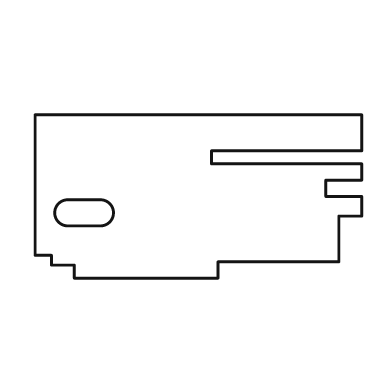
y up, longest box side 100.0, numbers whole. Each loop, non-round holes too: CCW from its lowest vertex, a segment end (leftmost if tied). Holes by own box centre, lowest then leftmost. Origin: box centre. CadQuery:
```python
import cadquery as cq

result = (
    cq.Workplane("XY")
    .moveTo(-38.0, -25.0)
    .lineTo(6.0, -25.0)
    .lineTo(6.0, -20.0)
    .lineTo(43.0, -20.0)
    .lineTo(43.0, -6.0)
    .lineTo(50.0, -6.0)
    .lineTo(50.0, 0.0)
    .lineTo(39.0, 0.0)
    .lineTo(39.0, 5.0)
    .lineTo(50.0, 5.0)
    .lineTo(50.0, 10.0)
    .lineTo(4.0, 10.0)
    .lineTo(4.0, 14.0)
    .lineTo(50.0, 14.0)
    .lineTo(50.0, 25.0)
    .lineTo(-50.0, 25.0)
    .lineTo(-50.0, -18.0)
    .lineTo(-45.0, -18.0)
    .lineTo(-45.0, -21.0)
    .lineTo(-38.0, -21.0)
    .close()
    .moveTo(-40.0, -9.0)
    .lineTo(-30.0, -9.0)
    .threePointArc((-26.0, -5.0), (-30.0, -1.0))
    .lineTo(-40.0, -1.0)
    .threePointArc((-44.0, -5.0), (-40.0, -9.0))
    .close()
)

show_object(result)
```